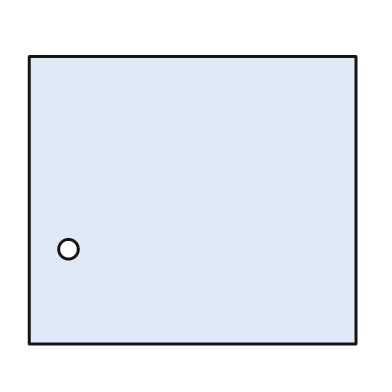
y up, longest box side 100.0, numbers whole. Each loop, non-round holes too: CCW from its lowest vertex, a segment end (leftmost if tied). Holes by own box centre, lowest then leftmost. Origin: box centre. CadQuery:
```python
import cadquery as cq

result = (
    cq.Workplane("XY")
    .moveTo(-50.0, -44.0)
    .lineTo(50.0, -44.0)
    .lineTo(50.0, 44.0)
    .lineTo(-50.0, 44.0)
    .close()
    .moveTo(-38.0, -15.0)
    .circle(3.0)
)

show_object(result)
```